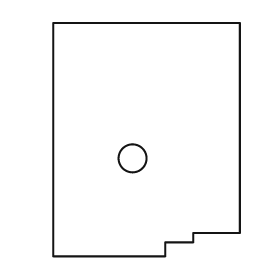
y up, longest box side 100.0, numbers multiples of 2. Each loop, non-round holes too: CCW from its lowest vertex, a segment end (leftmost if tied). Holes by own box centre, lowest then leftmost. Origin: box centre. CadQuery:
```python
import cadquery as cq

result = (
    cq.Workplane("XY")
    .moveTo(-40.0, -50.0)
    .lineTo(8.0, -50.0)
    .lineTo(8.0, -44.0)
    .lineTo(20.0, -44.0)
    .lineTo(20.0, -40.0)
    .lineTo(40.0, -40.0)
    .lineTo(40.0, 50.0)
    .lineTo(-40.0, 50.0)
    .close()
    .moveTo(-6.0, -8.0)
    .circle(6.0)
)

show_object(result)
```